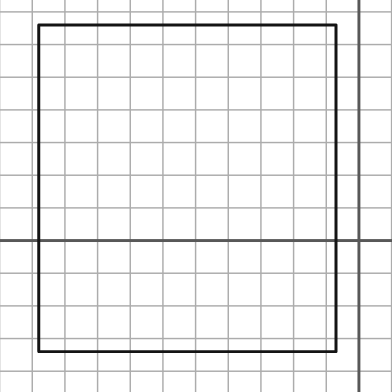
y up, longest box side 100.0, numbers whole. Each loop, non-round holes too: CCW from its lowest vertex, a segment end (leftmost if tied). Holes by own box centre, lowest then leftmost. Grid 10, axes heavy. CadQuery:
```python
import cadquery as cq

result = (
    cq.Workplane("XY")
    .moveTo(-98.0, -34.0)
    .lineTo(-7.0, -34.0)
    .lineTo(-7.0, 66.0)
    .lineTo(-98.0, 66.0)
    .close()
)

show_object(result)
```